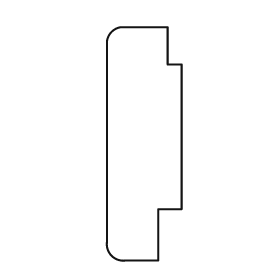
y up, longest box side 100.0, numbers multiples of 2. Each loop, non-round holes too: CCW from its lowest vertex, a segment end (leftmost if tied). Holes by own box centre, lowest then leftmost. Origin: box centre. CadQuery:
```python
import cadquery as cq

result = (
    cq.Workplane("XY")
    .moveTo(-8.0, -50.0)
    .lineTo(6.0, -50.0)
    .lineTo(6.0, -28.0)
    .lineTo(16.0, -28.0)
    .lineTo(16.0, 34.0)
    .lineTo(10.0, 34.0)
    .lineTo(10.0, 50.0)
    .lineTo(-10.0, 50.0)
    .threePointArc((-14.0, 48.0), (-16.0, 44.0))
    .lineTo(-16.0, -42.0)
    .threePointArc((-14.0, -48.0), (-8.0, -50.0))
    .close()
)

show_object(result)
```